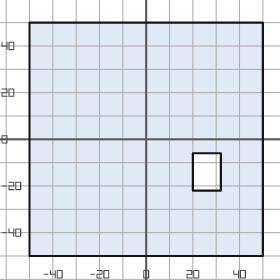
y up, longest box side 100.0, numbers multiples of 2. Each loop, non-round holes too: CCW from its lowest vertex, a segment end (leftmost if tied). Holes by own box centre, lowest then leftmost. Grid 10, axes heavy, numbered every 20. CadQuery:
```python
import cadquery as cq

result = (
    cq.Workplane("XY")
    .moveTo(-50.0, -50.0)
    .lineTo(50.0, -50.0)
    .lineTo(50.0, 50.0)
    .lineTo(-50.0, 50.0)
    .close()
    .moveTo(20.0, -22.0)
    .lineTo(32.0, -22.0)
    .lineTo(32.0, -6.0)
    .lineTo(20.0, -6.0)
    .close()
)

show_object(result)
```